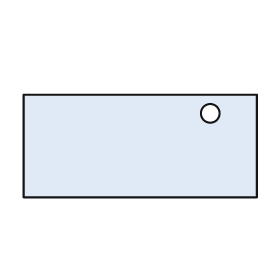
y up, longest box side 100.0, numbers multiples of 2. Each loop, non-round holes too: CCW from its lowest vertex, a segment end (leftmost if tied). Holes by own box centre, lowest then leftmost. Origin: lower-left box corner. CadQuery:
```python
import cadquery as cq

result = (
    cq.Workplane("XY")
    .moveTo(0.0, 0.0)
    .lineTo(100.0, 0.0)
    .lineTo(100.0, 44.0)
    .lineTo(0.0, 44.0)
    .close()
    .moveTo(80.0, 36.0)
    .circle(4.0)
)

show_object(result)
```